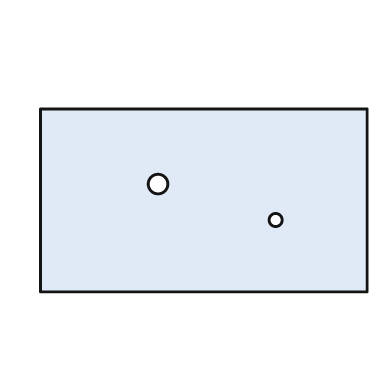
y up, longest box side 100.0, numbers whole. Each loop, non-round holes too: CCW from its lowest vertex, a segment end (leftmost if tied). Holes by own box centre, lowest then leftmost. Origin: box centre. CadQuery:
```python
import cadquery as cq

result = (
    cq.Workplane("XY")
    .moveTo(-50.0, -28.0)
    .lineTo(50.0, -28.0)
    .lineTo(50.0, 28.0)
    .lineTo(-50.0, 28.0)
    .close()
    .moveTo(22.0, -6.0)
    .circle(2.0)
    .moveTo(-14.0, 5.0)
    .circle(3.0)
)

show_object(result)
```